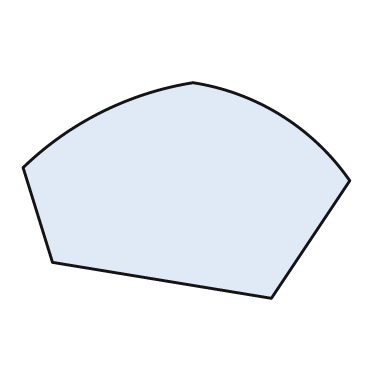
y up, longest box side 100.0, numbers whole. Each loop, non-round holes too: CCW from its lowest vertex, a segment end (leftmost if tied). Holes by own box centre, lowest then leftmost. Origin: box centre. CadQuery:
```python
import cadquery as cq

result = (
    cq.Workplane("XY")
    .moveTo(26.0, -33.0)
    .lineTo(50.0, 3.0)
    .threePointArc((29.0, 23.0), (2.0, 33.0))
    .threePointArc((-26.0, 24.0), (-50.0, 7.0))
    .lineTo(-41.0, -22.0)
    .close()
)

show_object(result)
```